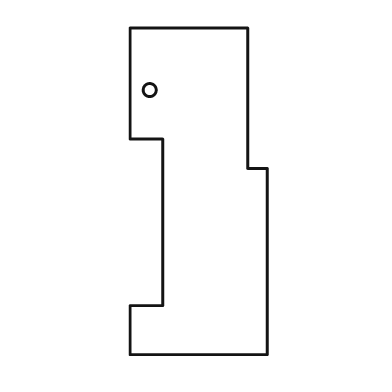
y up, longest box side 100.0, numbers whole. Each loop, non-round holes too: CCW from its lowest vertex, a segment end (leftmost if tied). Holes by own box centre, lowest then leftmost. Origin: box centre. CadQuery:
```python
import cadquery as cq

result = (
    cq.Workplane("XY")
    .moveTo(-21.0, -50.0)
    .lineTo(21.0, -50.0)
    .lineTo(21.0, 7.0)
    .lineTo(15.0, 7.0)
    .lineTo(15.0, 50.0)
    .lineTo(-21.0, 50.0)
    .lineTo(-21.0, 16.0)
    .lineTo(-11.0, 16.0)
    .lineTo(-11.0, -35.0)
    .lineTo(-21.0, -35.0)
    .close()
    .moveTo(-15.0, 31.0)
    .circle(2.0)
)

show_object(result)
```